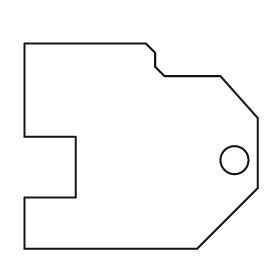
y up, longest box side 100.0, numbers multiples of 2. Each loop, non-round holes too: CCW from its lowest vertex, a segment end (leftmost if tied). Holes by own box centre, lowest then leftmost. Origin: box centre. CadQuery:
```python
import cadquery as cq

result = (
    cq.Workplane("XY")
    .moveTo(-50.0, -44.0)
    .lineTo(24.0, -44.0)
    .lineTo(50.0, -18.0)
    .lineTo(50.0, 12.0)
    .lineTo(34.0, 30.0)
    .lineTo(10.0, 30.0)
    .lineTo(6.0, 34.0)
    .lineTo(6.0, 40.0)
    .lineTo(2.0, 44.0)
    .lineTo(-50.0, 44.0)
    .lineTo(-50.0, 4.0)
    .lineTo(-28.0, 4.0)
    .lineTo(-28.0, -22.0)
    .lineTo(-50.0, -22.0)
    .close()
    .moveTo(40.0, -6.0)
    .circle(6.0)
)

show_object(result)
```